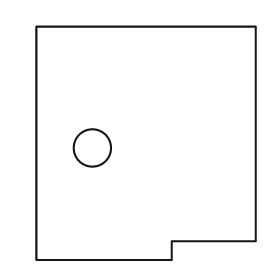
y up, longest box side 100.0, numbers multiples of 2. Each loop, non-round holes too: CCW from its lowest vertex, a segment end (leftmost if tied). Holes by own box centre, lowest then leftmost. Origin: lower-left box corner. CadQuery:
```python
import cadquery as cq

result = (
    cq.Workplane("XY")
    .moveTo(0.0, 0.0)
    .lineTo(58.0, 0.0)
    .lineTo(58.0, 8.0)
    .lineTo(94.0, 8.0)
    .lineTo(94.0, 100.0)
    .lineTo(0.0, 100.0)
    .close()
    .moveTo(24.0, 48.0)
    .circle(8.0)
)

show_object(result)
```